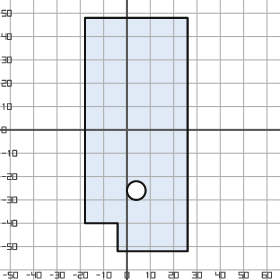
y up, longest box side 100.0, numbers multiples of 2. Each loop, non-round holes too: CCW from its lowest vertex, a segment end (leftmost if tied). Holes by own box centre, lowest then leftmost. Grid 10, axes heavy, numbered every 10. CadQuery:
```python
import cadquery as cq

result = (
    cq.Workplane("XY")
    .moveTo(-4.0, -52.0)
    .lineTo(26.0, -52.0)
    .lineTo(26.0, 48.0)
    .lineTo(-18.0, 48.0)
    .lineTo(-18.0, -40.0)
    .lineTo(-4.0, -40.0)
    .close()
    .moveTo(4.0, -26.0)
    .circle(4.0)
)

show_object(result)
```